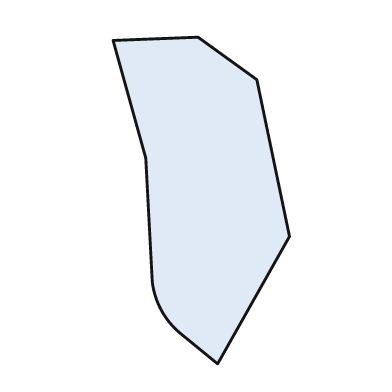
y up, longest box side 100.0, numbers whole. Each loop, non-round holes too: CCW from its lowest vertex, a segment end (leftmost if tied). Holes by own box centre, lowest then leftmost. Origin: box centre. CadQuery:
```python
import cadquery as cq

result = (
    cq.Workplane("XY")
    .moveTo(5.0, -50.0)
    .lineTo(27.0, -11.0)
    .lineTo(17.0, 37.0)
    .lineTo(-1.0, 50.0)
    .lineTo(-27.0, 49.0)
    .lineTo(-17.0, 13.0)
    .lineTo(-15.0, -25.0)
    .threePointArc((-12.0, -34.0), (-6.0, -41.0))
    .close()
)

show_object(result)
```